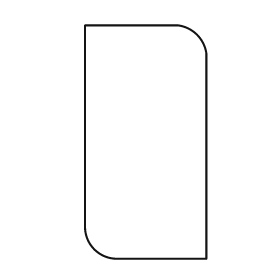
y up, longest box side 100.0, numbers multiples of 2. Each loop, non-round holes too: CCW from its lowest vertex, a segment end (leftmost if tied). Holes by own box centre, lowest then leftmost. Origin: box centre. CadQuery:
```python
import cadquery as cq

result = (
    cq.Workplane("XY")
    .moveTo(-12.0, -50.0)
    .lineTo(26.0, -50.0)
    .lineTo(26.0, 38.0)
    .threePointArc((22.0, 46.0), (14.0, 50.0))
    .lineTo(-26.0, 50.0)
    .lineTo(-26.0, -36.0)
    .threePointArc((-22.0, -46.0), (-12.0, -50.0))
    .close()
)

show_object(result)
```